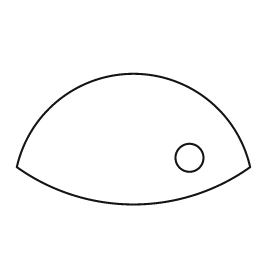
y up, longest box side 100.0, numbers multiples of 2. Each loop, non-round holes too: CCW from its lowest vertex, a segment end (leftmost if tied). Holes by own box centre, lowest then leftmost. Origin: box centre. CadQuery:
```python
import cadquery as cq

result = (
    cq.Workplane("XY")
    .moveTo(-50.0, -12.0)
    .threePointArc((0.0, -28.0), (50.0, -12.0))
    .threePointArc((0.0, 28.0), (-50.0, -12.0))
    .close()
    .moveTo(24.0, -8.0)
    .circle(6.0)
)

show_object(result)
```